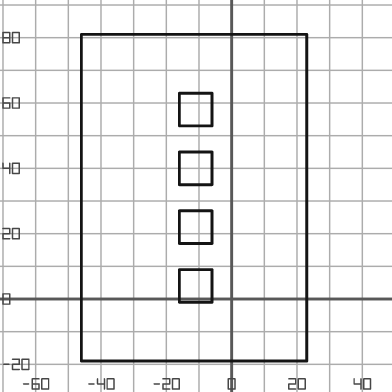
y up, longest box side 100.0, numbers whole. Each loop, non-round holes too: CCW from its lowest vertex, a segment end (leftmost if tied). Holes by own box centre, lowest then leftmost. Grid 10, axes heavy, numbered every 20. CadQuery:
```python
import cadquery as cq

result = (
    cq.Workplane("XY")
    .moveTo(-46.0, -19.0)
    .lineTo(23.0, -19.0)
    .lineTo(23.0, 81.0)
    .lineTo(-46.0, 81.0)
    .close()
    .moveTo(-16.0, -1.0)
    .lineTo(-6.0, -1.0)
    .lineTo(-6.0, 9.0)
    .lineTo(-16.0, 9.0)
    .close()
    .moveTo(-16.0, 17.0)
    .lineTo(-6.0, 17.0)
    .lineTo(-6.0, 27.0)
    .lineTo(-16.0, 27.0)
    .close()
    .moveTo(-16.0, 35.0)
    .lineTo(-6.0, 35.0)
    .lineTo(-6.0, 45.0)
    .lineTo(-16.0, 45.0)
    .close()
    .moveTo(-16.0, 53.0)
    .lineTo(-6.0, 53.0)
    .lineTo(-6.0, 63.0)
    .lineTo(-16.0, 63.0)
    .close()
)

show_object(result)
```